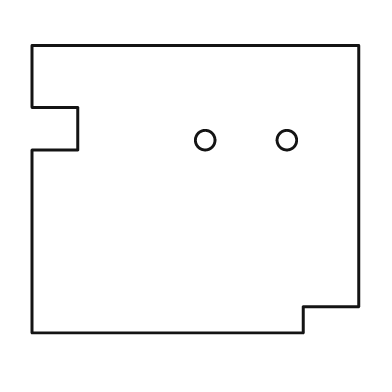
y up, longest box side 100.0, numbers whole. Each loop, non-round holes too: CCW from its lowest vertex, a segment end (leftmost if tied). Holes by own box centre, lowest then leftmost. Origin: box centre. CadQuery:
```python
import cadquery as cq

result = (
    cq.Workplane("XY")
    .moveTo(-50.0, -44.0)
    .lineTo(33.0, -44.0)
    .lineTo(33.0, -36.0)
    .lineTo(50.0, -36.0)
    .lineTo(50.0, 44.0)
    .lineTo(-50.0, 44.0)
    .lineTo(-50.0, 25.0)
    .lineTo(-36.0, 25.0)
    .lineTo(-36.0, 12.0)
    .lineTo(-50.0, 12.0)
    .close()
    .moveTo(3.0, 15.0)
    .circle(3.0)
    .moveTo(28.0, 15.0)
    .circle(3.0)
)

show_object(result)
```